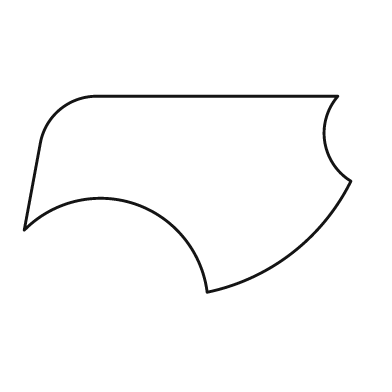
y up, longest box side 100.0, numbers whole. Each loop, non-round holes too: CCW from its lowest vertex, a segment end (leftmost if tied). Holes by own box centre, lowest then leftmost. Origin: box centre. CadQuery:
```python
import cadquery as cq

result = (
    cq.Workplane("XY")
    .moveTo(6.0, -30.0)
    .threePointArc((32.0, -18.0), (50.0, 4.0))
    .threePointArc((42.0, 16.0), (46.0, 30.0))
    .lineTo(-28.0, 30.0)
    .threePointArc((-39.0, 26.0), (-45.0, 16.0))
    .lineTo(-50.0, -11.0)
    .threePointArc((-16.0, -3.0), (6.0, -30.0))
    .close()
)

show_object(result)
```